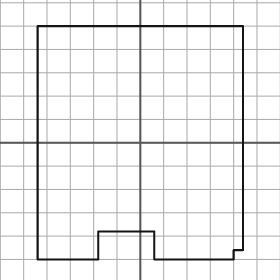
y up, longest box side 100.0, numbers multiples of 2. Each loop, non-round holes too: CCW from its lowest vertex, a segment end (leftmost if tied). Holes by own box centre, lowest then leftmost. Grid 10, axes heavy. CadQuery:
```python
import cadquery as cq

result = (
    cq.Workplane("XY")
    .moveTo(-44.0, -50.0)
    .lineTo(-18.0, -50.0)
    .lineTo(-18.0, -38.0)
    .lineTo(6.0, -38.0)
    .lineTo(6.0, -50.0)
    .lineTo(40.0, -50.0)
    .lineTo(40.0, -46.0)
    .lineTo(44.0, -46.0)
    .lineTo(44.0, 50.0)
    .lineTo(-44.0, 50.0)
    .close()
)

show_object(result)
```